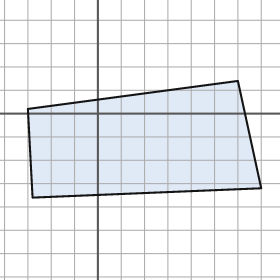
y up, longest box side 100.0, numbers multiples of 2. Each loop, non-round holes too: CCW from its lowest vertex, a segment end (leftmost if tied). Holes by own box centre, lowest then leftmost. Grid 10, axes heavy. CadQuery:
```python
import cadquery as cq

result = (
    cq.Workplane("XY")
    .moveTo(-28.0, -36.0)
    .lineTo(70.0, -32.0)
    .lineTo(60.0, 14.0)
    .lineTo(-30.0, 2.0)
    .close()
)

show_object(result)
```